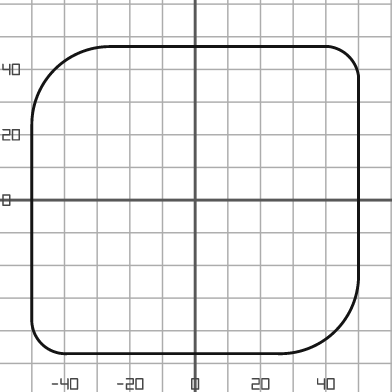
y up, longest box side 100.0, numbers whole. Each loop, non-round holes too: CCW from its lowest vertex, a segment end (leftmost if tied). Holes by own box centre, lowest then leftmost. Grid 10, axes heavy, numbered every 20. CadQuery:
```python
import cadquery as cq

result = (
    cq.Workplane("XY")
    .moveTo(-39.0, -47.0)
    .lineTo(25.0, -47.0)
    .threePointArc((43.0, -40.0), (50.0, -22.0))
    .lineTo(50.0, 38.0)
    .threePointArc((47.0, 44.0), (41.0, 47.0))
    .lineTo(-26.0, 47.0)
    .threePointArc((-43.0, 40.0), (-50.0, 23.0))
    .lineTo(-50.0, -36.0)
    .threePointArc((-47.0, -44.0), (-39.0, -47.0))
    .close()
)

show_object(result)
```